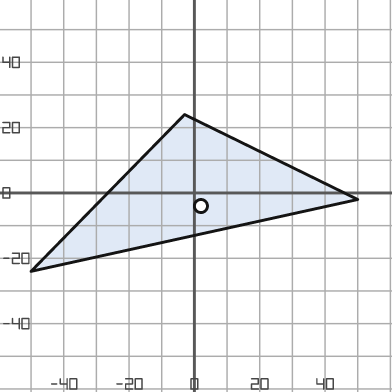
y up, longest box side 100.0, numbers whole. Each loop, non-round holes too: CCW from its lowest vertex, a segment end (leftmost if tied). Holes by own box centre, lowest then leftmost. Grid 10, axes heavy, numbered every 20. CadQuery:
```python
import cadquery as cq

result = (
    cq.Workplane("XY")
    .moveTo(-50.0, -24.0)
    .lineTo(50.0, -2.0)
    .lineTo(-3.0, 24.0)
    .close()
    .moveTo(2.0, -4.0)
    .circle(2.0)
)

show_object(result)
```